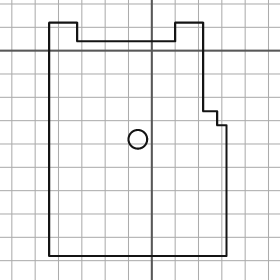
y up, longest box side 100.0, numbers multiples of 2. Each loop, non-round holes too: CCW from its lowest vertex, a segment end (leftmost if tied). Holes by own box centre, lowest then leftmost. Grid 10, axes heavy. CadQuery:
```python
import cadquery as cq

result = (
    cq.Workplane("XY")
    .moveTo(-44.0, -88.0)
    .lineTo(32.0, -88.0)
    .lineTo(32.0, -32.0)
    .lineTo(28.0, -32.0)
    .lineTo(28.0, -26.0)
    .lineTo(22.0, -26.0)
    .lineTo(22.0, 12.0)
    .lineTo(10.0, 12.0)
    .lineTo(10.0, 4.0)
    .lineTo(-32.0, 4.0)
    .lineTo(-32.0, 12.0)
    .lineTo(-44.0, 12.0)
    .close()
    .moveTo(-6.0, -38.0)
    .circle(4.0)
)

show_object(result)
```